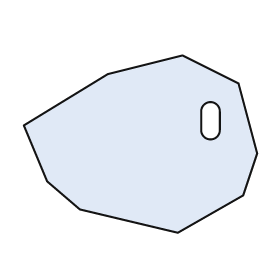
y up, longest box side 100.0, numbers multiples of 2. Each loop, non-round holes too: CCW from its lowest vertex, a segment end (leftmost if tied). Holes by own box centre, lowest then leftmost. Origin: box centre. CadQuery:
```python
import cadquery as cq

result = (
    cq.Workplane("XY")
    .moveTo(16.0, -38.0)
    .lineTo(44.0, -22.0)
    .lineTo(50.0, -4.0)
    .lineTo(42.0, 26.0)
    .lineTo(18.0, 38.0)
    .lineTo(-14.0, 30.0)
    .lineTo(-50.0, 8.0)
    .lineTo(-40.0, -16.0)
    .lineTo(-26.0, -28.0)
    .close()
    .moveTo(26.0, 6.0)
    .threePointArc((30.0, 2.0), (34.0, 6.0))
    .lineTo(34.0, 14.0)
    .threePointArc((30.0, 18.0), (26.0, 14.0))
    .close()
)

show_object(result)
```